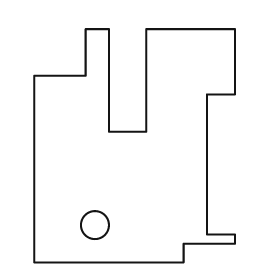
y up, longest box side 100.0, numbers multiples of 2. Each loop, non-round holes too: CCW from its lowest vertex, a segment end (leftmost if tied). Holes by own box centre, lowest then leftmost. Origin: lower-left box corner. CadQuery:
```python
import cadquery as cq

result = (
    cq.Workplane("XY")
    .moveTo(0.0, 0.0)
    .lineTo(64.0, 0.0)
    .lineTo(64.0, 8.0)
    .lineTo(86.0, 8.0)
    .lineTo(86.0, 12.0)
    .lineTo(74.0, 12.0)
    .lineTo(74.0, 72.0)
    .lineTo(86.0, 72.0)
    .lineTo(86.0, 100.0)
    .lineTo(48.0, 100.0)
    .lineTo(48.0, 56.0)
    .lineTo(32.0, 56.0)
    .lineTo(32.0, 100.0)
    .lineTo(22.0, 100.0)
    .lineTo(22.0, 80.0)
    .lineTo(0.0, 80.0)
    .close()
    .moveTo(26.0, 16.0)
    .circle(6.0)
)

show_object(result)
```